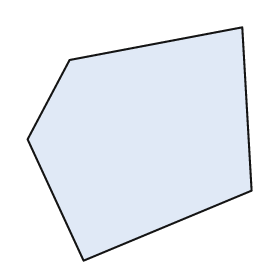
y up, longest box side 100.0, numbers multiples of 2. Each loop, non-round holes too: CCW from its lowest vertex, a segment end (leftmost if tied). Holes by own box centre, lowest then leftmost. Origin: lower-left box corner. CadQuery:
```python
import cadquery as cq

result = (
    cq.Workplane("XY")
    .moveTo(24.0, 0.0)
    .lineTo(96.0, 30.0)
    .lineTo(92.0, 100.0)
    .lineTo(18.0, 86.0)
    .lineTo(0.0, 52.0)
    .close()
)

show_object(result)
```